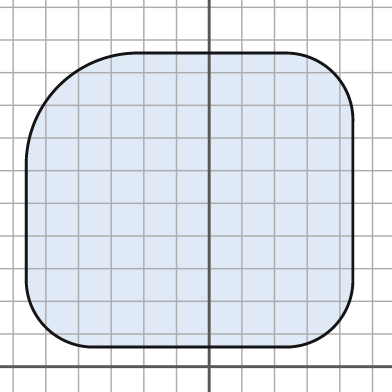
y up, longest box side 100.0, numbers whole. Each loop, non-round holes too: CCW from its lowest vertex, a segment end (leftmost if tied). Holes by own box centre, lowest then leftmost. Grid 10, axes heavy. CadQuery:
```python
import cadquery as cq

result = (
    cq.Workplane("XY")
    .moveTo(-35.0, 6.0)
    .lineTo(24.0, 6.0)
    .threePointArc((38.0, 12.0), (44.0, 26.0))
    .lineTo(44.0, 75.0)
    .threePointArc((38.0, 90.0), (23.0, 96.0))
    .lineTo(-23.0, 96.0)
    .threePointArc((-46.0, 86.0), (-56.0, 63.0))
    .lineTo(-56.0, 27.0)
    .threePointArc((-50.0, 12.0), (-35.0, 6.0))
    .close()
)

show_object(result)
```